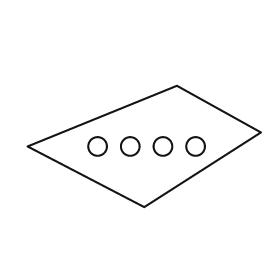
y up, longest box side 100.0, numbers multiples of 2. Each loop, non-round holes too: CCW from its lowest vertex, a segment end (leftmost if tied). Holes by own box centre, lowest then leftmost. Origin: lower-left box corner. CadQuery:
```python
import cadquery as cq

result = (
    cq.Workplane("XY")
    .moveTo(50.0, 0.0)
    .lineTo(100.0, 32.0)
    .lineTo(64.0, 52.0)
    .lineTo(0.0, 26.0)
    .close()
    .moveTo(30.0, 26.0)
    .circle(4.0)
    .moveTo(44.0, 26.0)
    .circle(4.0)
    .moveTo(58.0, 26.0)
    .circle(4.0)
    .moveTo(72.0, 26.0)
    .circle(4.0)
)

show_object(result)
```